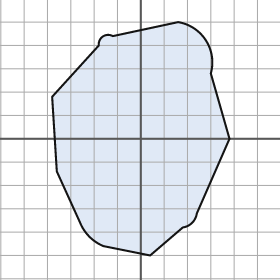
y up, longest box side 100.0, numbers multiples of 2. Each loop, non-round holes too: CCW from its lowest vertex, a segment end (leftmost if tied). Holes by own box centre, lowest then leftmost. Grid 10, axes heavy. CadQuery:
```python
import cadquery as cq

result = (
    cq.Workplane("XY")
    .moveTo(4.0, -50.0)
    .lineTo(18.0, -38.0)
    .threePointArc((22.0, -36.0), (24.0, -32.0))
    .lineTo(38.0, 0.0)
    .lineTo(30.0, 28.0)
    .threePointArc((28.0, 42.0), (16.0, 50.0))
    .lineTo(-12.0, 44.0)
    .threePointArc((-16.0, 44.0), (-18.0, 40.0))
    .lineTo(-38.0, 18.0)
    .lineTo(-36.0, -14.0)
    .lineTo(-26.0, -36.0)
    .threePointArc((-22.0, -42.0), (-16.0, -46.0))
    .close()
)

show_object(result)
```